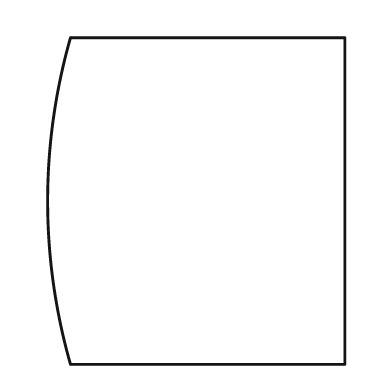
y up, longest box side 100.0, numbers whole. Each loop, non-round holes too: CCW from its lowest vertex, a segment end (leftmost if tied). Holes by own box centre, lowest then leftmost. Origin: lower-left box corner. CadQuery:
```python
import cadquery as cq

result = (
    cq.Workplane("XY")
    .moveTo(7.0, 0.0)
    .lineTo(91.0, 0.0)
    .lineTo(91.0, 100.0)
    .lineTo(7.0, 100.0)
    .threePointArc((0.0, 50.0), (7.0, 0.0))
    .close()
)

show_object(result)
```